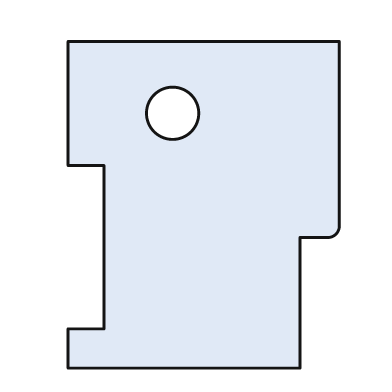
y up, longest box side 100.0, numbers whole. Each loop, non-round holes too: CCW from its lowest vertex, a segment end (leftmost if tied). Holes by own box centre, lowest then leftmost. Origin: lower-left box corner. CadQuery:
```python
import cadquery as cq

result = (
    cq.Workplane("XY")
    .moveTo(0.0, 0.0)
    .lineTo(71.0, 0.0)
    .lineTo(71.0, 40.0)
    .lineTo(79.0, 40.0)
    .threePointArc((82.0, 41.0), (83.0, 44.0))
    .lineTo(83.0, 100.0)
    .lineTo(0.0, 100.0)
    .lineTo(0.0, 62.0)
    .lineTo(11.0, 62.0)
    .lineTo(11.0, 12.0)
    .lineTo(0.0, 12.0)
    .close()
    .moveTo(32.0, 78.0)
    .circle(8.0)
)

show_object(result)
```